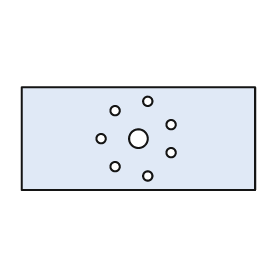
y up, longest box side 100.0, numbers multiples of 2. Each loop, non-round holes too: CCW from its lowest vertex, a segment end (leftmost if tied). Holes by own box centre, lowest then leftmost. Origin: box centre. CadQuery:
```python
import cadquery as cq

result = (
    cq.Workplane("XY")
    .moveTo(-50.0, -22.0)
    .lineTo(50.0, -22.0)
    .lineTo(50.0, 22.0)
    .lineTo(-50.0, 22.0)
    .close()
    .moveTo(4.0, -16.0)
    .circle(2.0)
    .moveTo(-10.0, -12.0)
    .circle(2.0)
    .moveTo(14.0, -6.0)
    .circle(2.0)
    .moveTo(-16.0, 0.0)
    .circle(2.0)
    .moveTo(0.0, 0.0)
    .circle(4.0)
    .moveTo(14.0, 6.0)
    .circle(2.0)
    .moveTo(-10.0, 12.0)
    .circle(2.0)
    .moveTo(4.0, 16.0)
    .circle(2.0)
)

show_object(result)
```